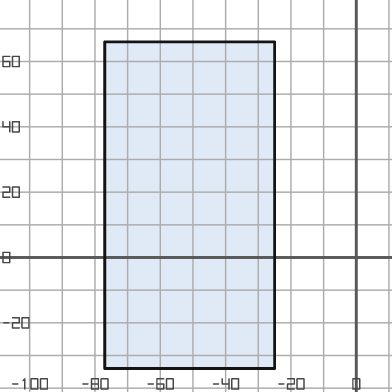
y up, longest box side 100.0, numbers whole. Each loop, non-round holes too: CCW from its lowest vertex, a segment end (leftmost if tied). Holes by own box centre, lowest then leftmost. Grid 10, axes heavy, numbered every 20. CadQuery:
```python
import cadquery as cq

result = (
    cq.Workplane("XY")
    .moveTo(-77.0, -34.0)
    .lineTo(-25.0, -34.0)
    .lineTo(-25.0, 66.0)
    .lineTo(-77.0, 66.0)
    .close()
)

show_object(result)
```